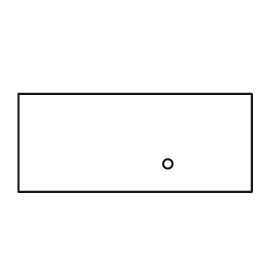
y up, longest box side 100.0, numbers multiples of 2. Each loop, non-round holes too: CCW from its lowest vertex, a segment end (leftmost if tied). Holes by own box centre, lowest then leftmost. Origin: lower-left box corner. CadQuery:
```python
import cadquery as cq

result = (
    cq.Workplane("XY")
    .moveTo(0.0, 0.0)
    .lineTo(100.0, 0.0)
    .lineTo(100.0, 42.0)
    .lineTo(0.0, 42.0)
    .close()
    .moveTo(64.0, 12.0)
    .circle(2.0)
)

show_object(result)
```